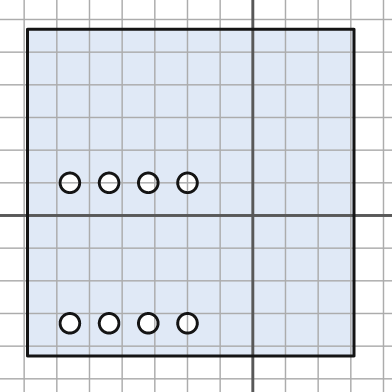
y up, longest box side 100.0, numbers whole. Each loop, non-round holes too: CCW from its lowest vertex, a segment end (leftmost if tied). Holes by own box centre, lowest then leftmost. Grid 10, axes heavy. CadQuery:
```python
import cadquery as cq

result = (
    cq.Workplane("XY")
    .moveTo(-69.0, -43.0)
    .lineTo(31.0, -43.0)
    .lineTo(31.0, 57.0)
    .lineTo(-69.0, 57.0)
    .close()
    .moveTo(-56.0, -33.0)
    .circle(3.0)
    .moveTo(-44.0, -33.0)
    .circle(3.0)
    .moveTo(-32.0, -33.0)
    .circle(3.0)
    .moveTo(-20.0, -33.0)
    .circle(3.0)
    .moveTo(-56.0, 10.0)
    .circle(3.0)
    .moveTo(-44.0, 10.0)
    .circle(3.0)
    .moveTo(-32.0, 10.0)
    .circle(3.0)
    .moveTo(-20.0, 10.0)
    .circle(3.0)
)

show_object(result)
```